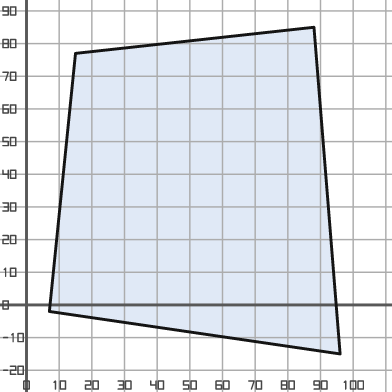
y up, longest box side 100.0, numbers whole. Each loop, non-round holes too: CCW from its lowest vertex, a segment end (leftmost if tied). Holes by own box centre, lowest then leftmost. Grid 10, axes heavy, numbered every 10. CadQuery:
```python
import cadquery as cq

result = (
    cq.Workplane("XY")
    .moveTo(96.0, -15.0)
    .lineTo(88.0, 85.0)
    .lineTo(15.0, 77.0)
    .lineTo(7.0, -2.0)
    .close()
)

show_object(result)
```